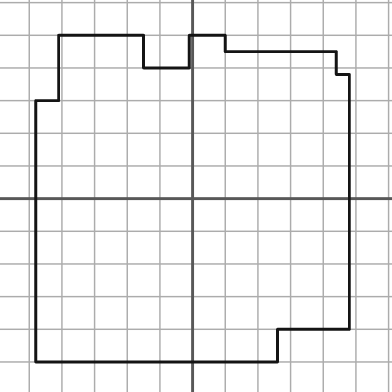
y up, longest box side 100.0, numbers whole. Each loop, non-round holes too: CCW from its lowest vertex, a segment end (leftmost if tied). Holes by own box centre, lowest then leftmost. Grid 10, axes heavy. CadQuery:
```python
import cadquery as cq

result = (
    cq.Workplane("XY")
    .moveTo(-48.0, -50.0)
    .lineTo(26.0, -50.0)
    .lineTo(26.0, -40.0)
    .lineTo(48.0, -40.0)
    .lineTo(48.0, 38.0)
    .lineTo(44.0, 38.0)
    .lineTo(44.0, 45.0)
    .lineTo(10.0, 45.0)
    .lineTo(10.0, 50.0)
    .lineTo(-1.0, 50.0)
    .lineTo(-1.0, 40.0)
    .lineTo(-15.0, 40.0)
    .lineTo(-15.0, 50.0)
    .lineTo(-41.0, 50.0)
    .lineTo(-41.0, 30.0)
    .lineTo(-48.0, 30.0)
    .close()
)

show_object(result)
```